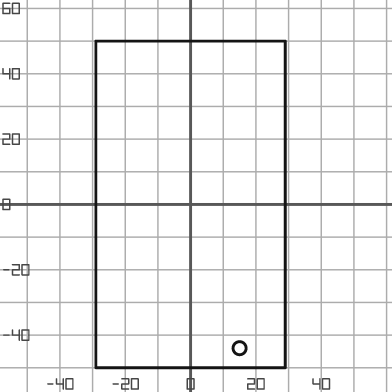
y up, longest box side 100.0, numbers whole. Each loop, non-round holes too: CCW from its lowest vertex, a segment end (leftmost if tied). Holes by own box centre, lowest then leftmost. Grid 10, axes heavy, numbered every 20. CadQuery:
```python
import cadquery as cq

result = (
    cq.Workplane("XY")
    .moveTo(-29.0, -50.0)
    .lineTo(29.0, -50.0)
    .lineTo(29.0, 50.0)
    .lineTo(-29.0, 50.0)
    .close()
    .moveTo(15.0, -44.0)
    .circle(2.0)
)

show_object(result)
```